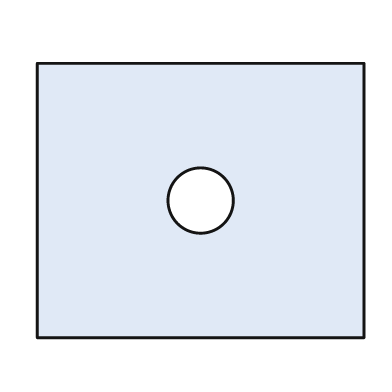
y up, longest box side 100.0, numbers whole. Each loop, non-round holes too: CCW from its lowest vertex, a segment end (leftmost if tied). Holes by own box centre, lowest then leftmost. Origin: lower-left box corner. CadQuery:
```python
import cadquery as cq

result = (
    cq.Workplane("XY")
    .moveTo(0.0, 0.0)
    .lineTo(100.0, 0.0)
    .lineTo(100.0, 84.0)
    .lineTo(0.0, 84.0)
    .close()
    .moveTo(50.0, 42.0)
    .circle(10.0)
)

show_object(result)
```